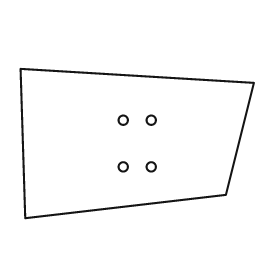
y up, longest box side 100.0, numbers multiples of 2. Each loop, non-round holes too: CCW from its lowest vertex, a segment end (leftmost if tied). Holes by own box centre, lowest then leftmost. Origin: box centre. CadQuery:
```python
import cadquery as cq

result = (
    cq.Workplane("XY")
    .moveTo(-48.0, -32.0)
    .lineTo(38.0, -22.0)
    .lineTo(50.0, 26.0)
    .lineTo(-50.0, 32.0)
    .close()
    .moveTo(-6.0, -10.0)
    .circle(2.0)
    .moveTo(6.0, -10.0)
    .circle(2.0)
    .moveTo(-6.0, 10.0)
    .circle(2.0)
    .moveTo(6.0, 10.0)
    .circle(2.0)
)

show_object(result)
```